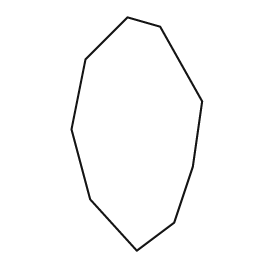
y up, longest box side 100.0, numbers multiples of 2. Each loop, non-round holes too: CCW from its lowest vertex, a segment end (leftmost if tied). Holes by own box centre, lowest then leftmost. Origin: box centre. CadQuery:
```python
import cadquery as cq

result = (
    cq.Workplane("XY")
    .moveTo(0.0, -50.0)
    .lineTo(16.0, -38.0)
    .lineTo(24.0, -14.0)
    .lineTo(28.0, 14.0)
    .lineTo(10.0, 46.0)
    .lineTo(-4.0, 50.0)
    .lineTo(-22.0, 32.0)
    .lineTo(-28.0, 2.0)
    .lineTo(-20.0, -28.0)
    .close()
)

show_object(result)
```